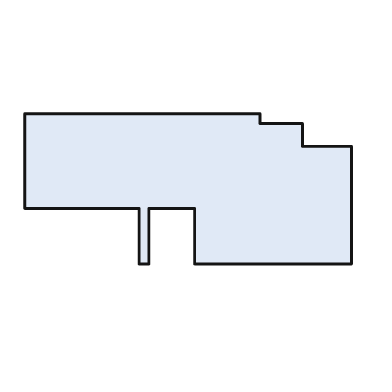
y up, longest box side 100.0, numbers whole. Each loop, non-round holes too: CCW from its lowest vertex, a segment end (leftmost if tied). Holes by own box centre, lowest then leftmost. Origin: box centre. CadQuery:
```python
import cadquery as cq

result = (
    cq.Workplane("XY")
    .moveTo(-15.0, -23.0)
    .lineTo(-12.0, -23.0)
    .lineTo(-12.0, -6.0)
    .lineTo(2.0, -6.0)
    .lineTo(2.0, -23.0)
    .lineTo(50.0, -23.0)
    .lineTo(50.0, 13.0)
    .lineTo(35.0, 13.0)
    .lineTo(35.0, 20.0)
    .lineTo(22.0, 20.0)
    .lineTo(22.0, 23.0)
    .lineTo(-50.0, 23.0)
    .lineTo(-50.0, -6.0)
    .lineTo(-15.0, -6.0)
    .close()
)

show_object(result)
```